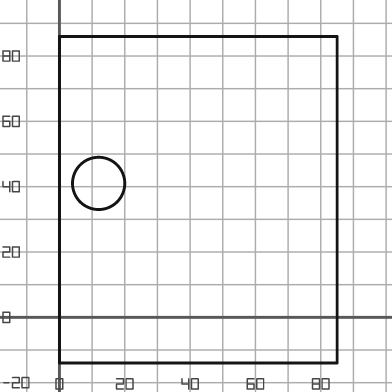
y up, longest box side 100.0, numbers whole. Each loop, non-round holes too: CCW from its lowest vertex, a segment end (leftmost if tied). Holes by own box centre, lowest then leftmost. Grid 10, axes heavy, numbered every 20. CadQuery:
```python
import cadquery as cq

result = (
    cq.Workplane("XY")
    .moveTo(0.0, -14.0)
    .lineTo(85.0, -14.0)
    .lineTo(85.0, 86.0)
    .lineTo(0.0, 86.0)
    .close()
    .moveTo(12.0, 41.0)
    .circle(8.0)
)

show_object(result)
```